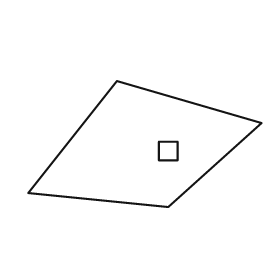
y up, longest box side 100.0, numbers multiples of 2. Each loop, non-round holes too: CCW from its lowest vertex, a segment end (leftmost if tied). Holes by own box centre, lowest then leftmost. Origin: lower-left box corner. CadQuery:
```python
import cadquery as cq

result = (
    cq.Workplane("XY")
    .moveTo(60.0, 0.0)
    .lineTo(100.0, 36.0)
    .lineTo(38.0, 54.0)
    .lineTo(0.0, 6.0)
    .close()
    .moveTo(56.0, 20.0)
    .lineTo(64.0, 20.0)
    .lineTo(64.0, 28.0)
    .lineTo(56.0, 28.0)
    .close()
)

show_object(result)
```